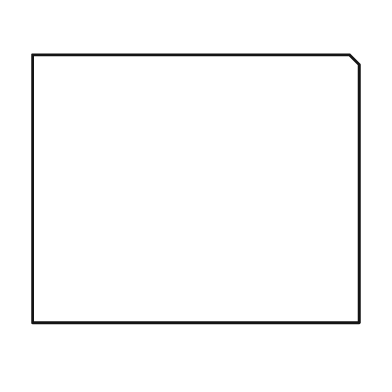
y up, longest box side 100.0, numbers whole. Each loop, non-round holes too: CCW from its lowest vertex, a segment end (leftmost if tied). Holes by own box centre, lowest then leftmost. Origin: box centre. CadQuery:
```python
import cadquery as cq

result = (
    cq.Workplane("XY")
    .moveTo(-50.0, -41.0)
    .lineTo(50.0, -41.0)
    .lineTo(50.0, 38.0)
    .lineTo(47.0, 41.0)
    .lineTo(-50.0, 41.0)
    .close()
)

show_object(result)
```